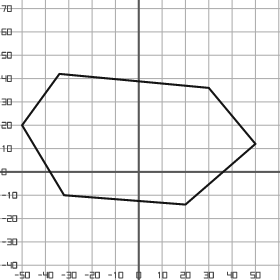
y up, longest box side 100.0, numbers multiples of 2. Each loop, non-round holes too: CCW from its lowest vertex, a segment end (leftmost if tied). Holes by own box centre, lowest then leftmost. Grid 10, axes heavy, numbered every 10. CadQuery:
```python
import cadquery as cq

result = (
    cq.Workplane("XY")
    .moveTo(20.0, -14.0)
    .lineTo(50.0, 12.0)
    .lineTo(30.0, 36.0)
    .lineTo(-34.0, 42.0)
    .lineTo(-50.0, 20.0)
    .lineTo(-32.0, -10.0)
    .close()
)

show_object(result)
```